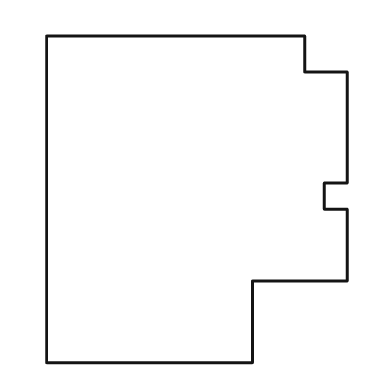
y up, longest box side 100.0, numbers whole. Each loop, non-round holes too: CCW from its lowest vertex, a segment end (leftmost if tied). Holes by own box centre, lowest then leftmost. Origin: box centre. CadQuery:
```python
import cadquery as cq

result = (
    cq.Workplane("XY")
    .moveTo(-46.0, -50.0)
    .lineTo(17.0, -50.0)
    .lineTo(17.0, -25.0)
    .lineTo(46.0, -25.0)
    .lineTo(46.0, -3.0)
    .lineTo(39.0, -3.0)
    .lineTo(39.0, 5.0)
    .lineTo(46.0, 5.0)
    .lineTo(46.0, 39.0)
    .lineTo(33.0, 39.0)
    .lineTo(33.0, 50.0)
    .lineTo(-46.0, 50.0)
    .close()
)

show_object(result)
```